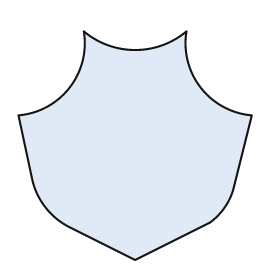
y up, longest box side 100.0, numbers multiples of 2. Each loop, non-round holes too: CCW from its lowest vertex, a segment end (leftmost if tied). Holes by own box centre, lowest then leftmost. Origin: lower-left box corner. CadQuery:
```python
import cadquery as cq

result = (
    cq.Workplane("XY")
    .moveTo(50.0, 0.0)
    .lineTo(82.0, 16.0)
    .threePointArc((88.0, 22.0), (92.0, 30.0))
    .lineTo(100.0, 62.0)
    .threePointArc((78.0, 74.0), (72.0, 98.0))
    .threePointArc((50.0, 90.0), (28.0, 98.0))
    .threePointArc((22.0, 74.0), (0.0, 62.0))
    .lineTo(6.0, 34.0)
    .threePointArc((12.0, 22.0), (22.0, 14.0))
    .close()
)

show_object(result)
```